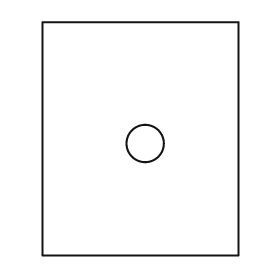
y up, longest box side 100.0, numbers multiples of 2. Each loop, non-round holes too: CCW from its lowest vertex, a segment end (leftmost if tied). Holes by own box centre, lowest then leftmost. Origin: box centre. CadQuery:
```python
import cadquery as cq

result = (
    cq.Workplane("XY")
    .moveTo(-42.0, -50.0)
    .lineTo(42.0, -50.0)
    .lineTo(42.0, 50.0)
    .lineTo(-42.0, 50.0)
    .close()
    .moveTo(2.0, -2.0)
    .circle(8.0)
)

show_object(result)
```